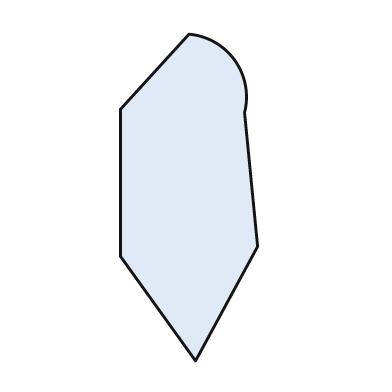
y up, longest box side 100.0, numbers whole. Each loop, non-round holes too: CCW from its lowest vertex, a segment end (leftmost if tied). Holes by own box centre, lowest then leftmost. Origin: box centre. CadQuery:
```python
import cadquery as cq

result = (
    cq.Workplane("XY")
    .moveTo(2.0, -50.0)
    .lineTo(21.0, -15.0)
    .lineTo(17.0, 26.0)
    .threePointArc((14.0, 42.0), (0.0, 50.0))
    .lineTo(-21.0, 27.0)
    .lineTo(-21.0, -18.0)
    .close()
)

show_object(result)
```